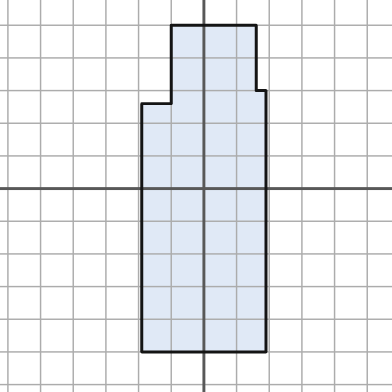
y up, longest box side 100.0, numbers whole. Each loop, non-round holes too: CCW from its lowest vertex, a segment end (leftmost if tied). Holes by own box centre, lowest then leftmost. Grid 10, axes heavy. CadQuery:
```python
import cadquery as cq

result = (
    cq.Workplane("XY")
    .moveTo(-19.0, -50.0)
    .lineTo(19.0, -50.0)
    .lineTo(19.0, 30.0)
    .lineTo(16.0, 30.0)
    .lineTo(16.0, 50.0)
    .lineTo(-10.0, 50.0)
    .lineTo(-10.0, 26.0)
    .lineTo(-19.0, 26.0)
    .close()
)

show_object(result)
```